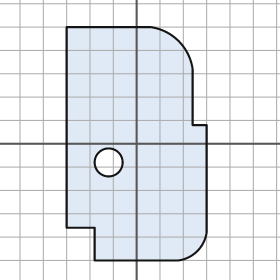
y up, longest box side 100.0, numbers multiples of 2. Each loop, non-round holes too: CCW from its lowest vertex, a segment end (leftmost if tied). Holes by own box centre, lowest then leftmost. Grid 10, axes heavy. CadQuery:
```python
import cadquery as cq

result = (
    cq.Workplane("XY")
    .moveTo(-18.0, -50.0)
    .lineTo(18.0, -50.0)
    .threePointArc((26.0, -46.0), (30.0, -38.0))
    .lineTo(30.0, 8.0)
    .lineTo(24.0, 8.0)
    .lineTo(24.0, 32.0)
    .threePointArc((18.0, 44.0), (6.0, 50.0))
    .lineTo(-30.0, 50.0)
    .lineTo(-30.0, -36.0)
    .lineTo(-18.0, -36.0)
    .close()
    .moveTo(-12.0, -8.0)
    .circle(6.0)
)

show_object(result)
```